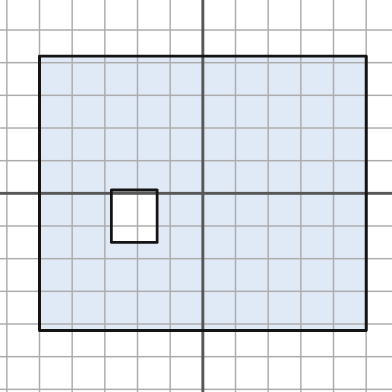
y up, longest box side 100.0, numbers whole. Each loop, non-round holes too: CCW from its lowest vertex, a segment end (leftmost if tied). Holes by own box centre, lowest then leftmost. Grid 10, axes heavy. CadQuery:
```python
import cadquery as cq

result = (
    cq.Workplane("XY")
    .moveTo(-50.0, -42.0)
    .lineTo(50.0, -42.0)
    .lineTo(50.0, 42.0)
    .lineTo(-50.0, 42.0)
    .close()
    .moveTo(-28.0, -15.0)
    .lineTo(-14.0, -15.0)
    .lineTo(-14.0, 1.0)
    .lineTo(-28.0, 1.0)
    .close()
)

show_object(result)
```